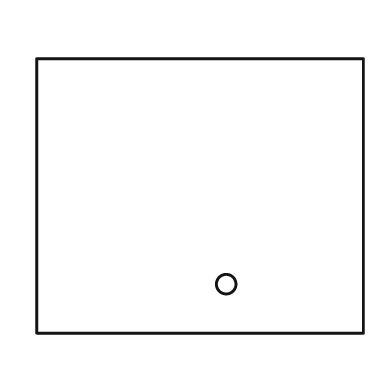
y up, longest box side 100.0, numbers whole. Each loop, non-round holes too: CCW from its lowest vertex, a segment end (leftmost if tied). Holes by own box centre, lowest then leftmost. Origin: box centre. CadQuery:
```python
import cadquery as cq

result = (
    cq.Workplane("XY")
    .moveTo(-50.0, -42.0)
    .lineTo(50.0, -42.0)
    .lineTo(50.0, 42.0)
    .lineTo(-50.0, 42.0)
    .close()
    .moveTo(8.0, -27.0)
    .circle(3.0)
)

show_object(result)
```